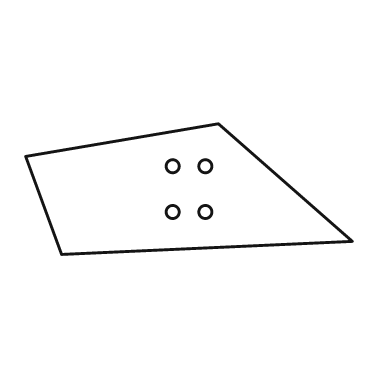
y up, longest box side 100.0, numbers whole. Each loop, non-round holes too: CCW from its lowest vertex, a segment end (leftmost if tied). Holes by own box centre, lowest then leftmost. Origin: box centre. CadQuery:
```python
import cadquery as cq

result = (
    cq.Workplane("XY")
    .moveTo(-39.0, -20.0)
    .lineTo(50.0, -16.0)
    .lineTo(9.0, 20.0)
    .lineTo(-50.0, 10.0)
    .close()
    .moveTo(-5.0, -7.0)
    .circle(2.0)
    .moveTo(5.0, -7.0)
    .circle(2.0)
    .moveTo(-5.0, 7.0)
    .circle(2.0)
    .moveTo(5.0, 7.0)
    .circle(2.0)
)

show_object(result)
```